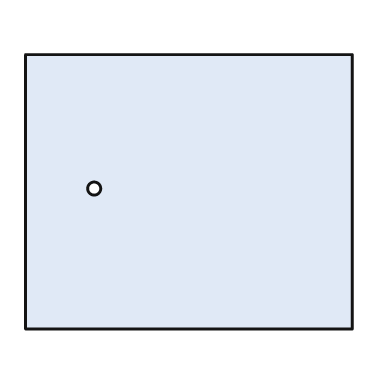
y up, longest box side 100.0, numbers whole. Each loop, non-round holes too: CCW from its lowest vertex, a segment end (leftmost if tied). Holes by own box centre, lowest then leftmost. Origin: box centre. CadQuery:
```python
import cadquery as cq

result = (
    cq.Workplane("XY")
    .moveTo(-50.0, -42.0)
    .lineTo(50.0, -42.0)
    .lineTo(50.0, 42.0)
    .lineTo(-50.0, 42.0)
    .close()
    .moveTo(-29.0, 1.0)
    .circle(2.0)
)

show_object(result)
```